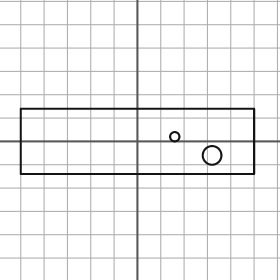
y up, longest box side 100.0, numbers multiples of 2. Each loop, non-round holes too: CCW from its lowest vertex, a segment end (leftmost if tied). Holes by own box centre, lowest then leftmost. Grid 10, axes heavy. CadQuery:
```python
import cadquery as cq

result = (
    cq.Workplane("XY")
    .moveTo(-50.0, -14.0)
    .lineTo(50.0, -14.0)
    .lineTo(50.0, 14.0)
    .lineTo(-50.0, 14.0)
    .close()
    .moveTo(32.0, -6.0)
    .circle(4.0)
    .moveTo(16.0, 2.0)
    .circle(2.0)
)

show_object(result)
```